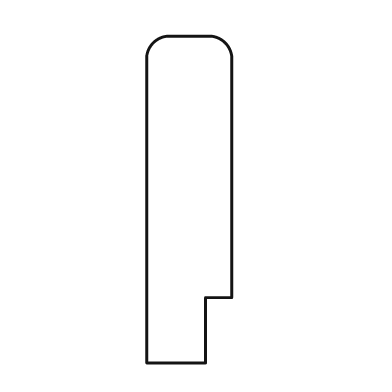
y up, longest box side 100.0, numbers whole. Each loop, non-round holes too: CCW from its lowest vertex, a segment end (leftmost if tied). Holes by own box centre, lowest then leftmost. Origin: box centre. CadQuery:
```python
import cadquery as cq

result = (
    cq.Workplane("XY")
    .moveTo(-13.0, -50.0)
    .lineTo(5.0, -50.0)
    .lineTo(5.0, -30.0)
    .lineTo(13.0, -30.0)
    .lineTo(13.0, 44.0)
    .threePointArc((11.0, 48.0), (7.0, 50.0))
    .lineTo(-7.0, 50.0)
    .threePointArc((-11.0, 48.0), (-13.0, 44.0))
    .close()
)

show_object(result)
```